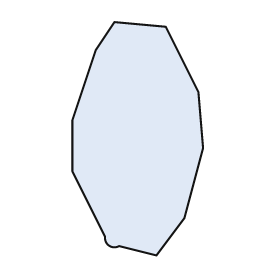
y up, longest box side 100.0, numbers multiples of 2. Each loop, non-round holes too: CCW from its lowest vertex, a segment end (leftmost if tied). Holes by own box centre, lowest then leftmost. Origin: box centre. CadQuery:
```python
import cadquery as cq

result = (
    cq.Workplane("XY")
    .moveTo(8.0, -50.0)
    .lineTo(20.0, -34.0)
    .lineTo(28.0, -4.0)
    .lineTo(26.0, 20.0)
    .lineTo(12.0, 48.0)
    .lineTo(-10.0, 50.0)
    .lineTo(-18.0, 38.0)
    .lineTo(-28.0, 8.0)
    .lineTo(-28.0, -14.0)
    .lineTo(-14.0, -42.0)
    .threePointArc((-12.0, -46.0), (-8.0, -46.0))
    .close()
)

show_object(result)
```